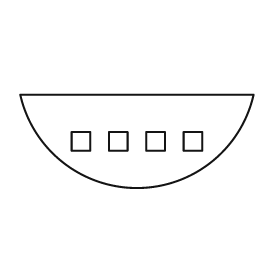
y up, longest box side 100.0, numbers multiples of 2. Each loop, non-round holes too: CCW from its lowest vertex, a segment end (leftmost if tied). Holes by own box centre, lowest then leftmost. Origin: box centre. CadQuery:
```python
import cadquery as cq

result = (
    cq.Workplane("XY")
    .moveTo(-50.0, 20.0)
    .threePointArc((0.0, -20.0), (50.0, 20.0))
    .close()
    .moveTo(-28.0, -4.0)
    .lineTo(-20.0, -4.0)
    .lineTo(-20.0, 4.0)
    .lineTo(-28.0, 4.0)
    .close()
    .moveTo(-12.0, -4.0)
    .lineTo(-4.0, -4.0)
    .lineTo(-4.0, 4.0)
    .lineTo(-12.0, 4.0)
    .close()
    .moveTo(4.0, -4.0)
    .lineTo(12.0, -4.0)
    .lineTo(12.0, 4.0)
    .lineTo(4.0, 4.0)
    .close()
    .moveTo(20.0, -4.0)
    .lineTo(28.0, -4.0)
    .lineTo(28.0, 4.0)
    .lineTo(20.0, 4.0)
    .close()
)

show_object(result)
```